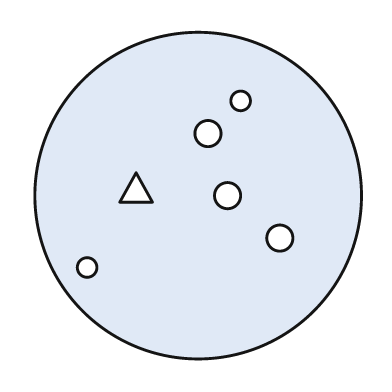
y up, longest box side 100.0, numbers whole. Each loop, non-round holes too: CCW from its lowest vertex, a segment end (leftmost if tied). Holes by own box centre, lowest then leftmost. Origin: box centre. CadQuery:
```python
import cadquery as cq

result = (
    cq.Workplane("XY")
    .moveTo(0.0, 0.0)
    .circle(50.0)
    .moveTo(-34.0, -22.0)
    .circle(3.0)
    .moveTo(25.0, -13.0)
    .circle(4.0)
    .moveTo(9.0, 0.0)
    .circle(4.0)
    .moveTo(-24.0, -2.0)
    .lineTo(-14.0, -2.0)
    .lineTo(-19.0, 7.0)
    .close()
    .moveTo(3.0, 19.0)
    .circle(4.0)
    .moveTo(13.0, 29.0)
    .circle(3.0)
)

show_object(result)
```